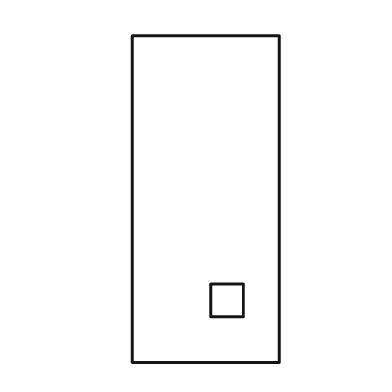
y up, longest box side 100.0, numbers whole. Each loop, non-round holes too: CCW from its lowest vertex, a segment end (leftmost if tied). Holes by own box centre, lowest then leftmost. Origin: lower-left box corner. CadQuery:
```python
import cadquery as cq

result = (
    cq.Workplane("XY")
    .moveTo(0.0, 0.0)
    .lineTo(45.0, 0.0)
    .lineTo(45.0, 100.0)
    .lineTo(0.0, 100.0)
    .close()
    .moveTo(24.0, 14.0)
    .lineTo(34.0, 14.0)
    .lineTo(34.0, 24.0)
    .lineTo(24.0, 24.0)
    .close()
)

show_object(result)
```